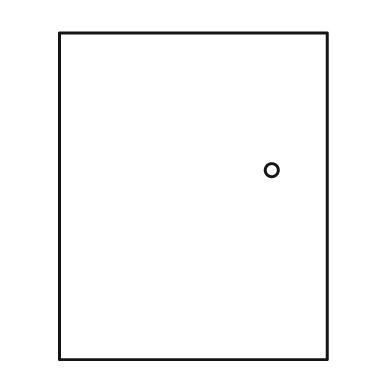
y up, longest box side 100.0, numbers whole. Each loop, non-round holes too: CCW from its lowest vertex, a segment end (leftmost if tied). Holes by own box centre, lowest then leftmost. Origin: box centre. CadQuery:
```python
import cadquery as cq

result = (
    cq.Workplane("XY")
    .moveTo(-41.0, -50.0)
    .lineTo(41.0, -50.0)
    .lineTo(41.0, 50.0)
    .lineTo(-41.0, 50.0)
    .close()
    .moveTo(24.0, 8.0)
    .circle(2.0)
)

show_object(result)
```